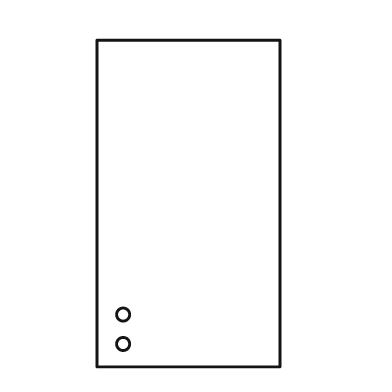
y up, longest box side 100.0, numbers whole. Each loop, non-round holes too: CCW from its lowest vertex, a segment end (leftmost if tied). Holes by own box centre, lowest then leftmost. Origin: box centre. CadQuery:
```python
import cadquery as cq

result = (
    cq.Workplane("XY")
    .moveTo(-28.0, -50.0)
    .lineTo(28.0, -50.0)
    .lineTo(28.0, 50.0)
    .lineTo(-28.0, 50.0)
    .close()
    .moveTo(-20.0, -43.0)
    .circle(2.0)
    .moveTo(-20.0, -34.0)
    .circle(2.0)
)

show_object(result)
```